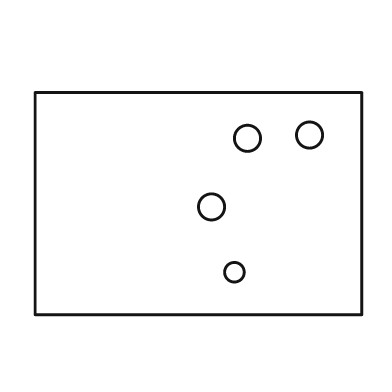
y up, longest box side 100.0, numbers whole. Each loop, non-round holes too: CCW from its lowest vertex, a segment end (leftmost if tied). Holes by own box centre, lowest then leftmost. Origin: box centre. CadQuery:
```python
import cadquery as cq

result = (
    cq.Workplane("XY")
    .moveTo(-50.0, -34.0)
    .lineTo(50.0, -34.0)
    .lineTo(50.0, 34.0)
    .lineTo(-50.0, 34.0)
    .close()
    .moveTo(11.0, -21.0)
    .circle(3.0)
    .moveTo(4.0, -1.0)
    .circle(4.0)
    .moveTo(15.0, 20.0)
    .circle(4.0)
    .moveTo(34.0, 21.0)
    .circle(4.0)
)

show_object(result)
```